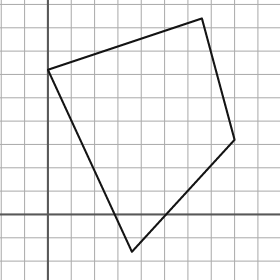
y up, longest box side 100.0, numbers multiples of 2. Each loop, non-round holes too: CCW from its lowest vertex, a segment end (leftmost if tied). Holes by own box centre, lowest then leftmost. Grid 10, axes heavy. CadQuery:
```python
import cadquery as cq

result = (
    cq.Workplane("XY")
    .moveTo(36.0, -16.0)
    .lineTo(80.0, 32.0)
    .lineTo(66.0, 84.0)
    .lineTo(0.0, 62.0)
    .close()
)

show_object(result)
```